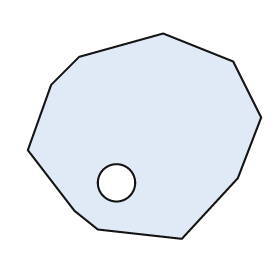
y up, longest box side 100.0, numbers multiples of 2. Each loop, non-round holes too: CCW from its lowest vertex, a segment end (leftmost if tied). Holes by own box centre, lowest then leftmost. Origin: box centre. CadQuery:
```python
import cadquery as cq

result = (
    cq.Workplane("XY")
    .moveTo(16.0, -44.0)
    .lineTo(40.0, -18.0)
    .lineTo(50.0, 8.0)
    .lineTo(38.0, 32.0)
    .lineTo(8.0, 44.0)
    .lineTo(-28.0, 34.0)
    .lineTo(-40.0, 22.0)
    .lineTo(-50.0, -6.0)
    .lineTo(-30.0, -32.0)
    .lineTo(-20.0, -40.0)
    .close()
    .moveTo(-12.0, -20.0)
    .circle(8.0)
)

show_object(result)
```